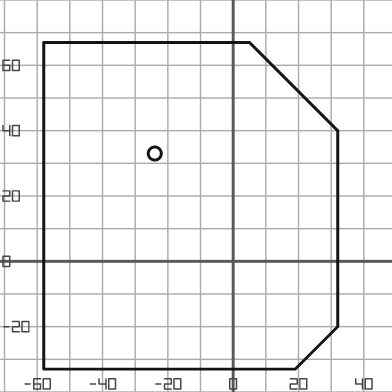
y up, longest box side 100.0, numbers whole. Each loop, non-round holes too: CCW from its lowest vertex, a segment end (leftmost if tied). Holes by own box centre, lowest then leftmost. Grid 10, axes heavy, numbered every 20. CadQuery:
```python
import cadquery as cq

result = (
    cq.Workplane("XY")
    .moveTo(-58.0, -33.0)
    .lineTo(19.0, -33.0)
    .lineTo(32.0, -20.0)
    .lineTo(32.0, 40.0)
    .lineTo(5.0, 67.0)
    .lineTo(-58.0, 67.0)
    .close()
    .moveTo(-24.0, 33.0)
    .circle(2.0)
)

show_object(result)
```